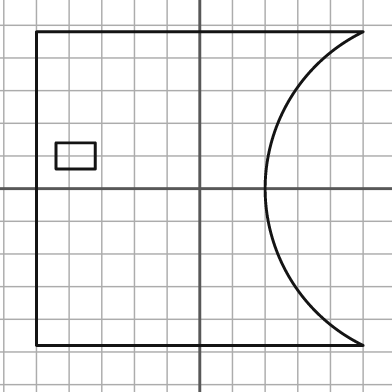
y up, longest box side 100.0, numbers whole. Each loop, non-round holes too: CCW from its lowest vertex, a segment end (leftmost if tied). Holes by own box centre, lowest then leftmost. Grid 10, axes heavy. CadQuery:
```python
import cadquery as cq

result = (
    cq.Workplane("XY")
    .moveTo(-50.0, -48.0)
    .lineTo(50.0, -48.0)
    .threePointArc((20.0, 0.0), (50.0, 48.0))
    .lineTo(-50.0, 48.0)
    .close()
    .moveTo(-44.0, 6.0)
    .lineTo(-32.0, 6.0)
    .lineTo(-32.0, 14.0)
    .lineTo(-44.0, 14.0)
    .close()
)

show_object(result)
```